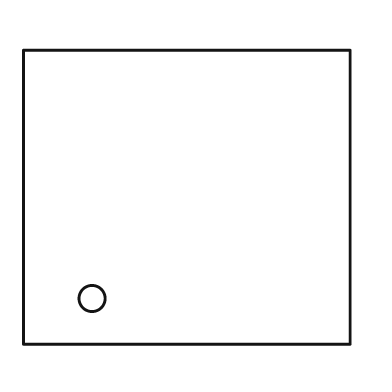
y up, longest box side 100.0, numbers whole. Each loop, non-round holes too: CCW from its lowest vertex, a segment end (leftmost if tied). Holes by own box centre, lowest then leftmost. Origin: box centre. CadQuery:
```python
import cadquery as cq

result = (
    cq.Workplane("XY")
    .moveTo(-50.0, -45.0)
    .lineTo(50.0, -45.0)
    .lineTo(50.0, 45.0)
    .lineTo(-50.0, 45.0)
    .close()
    .moveTo(-29.0, -31.0)
    .circle(4.0)
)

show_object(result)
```